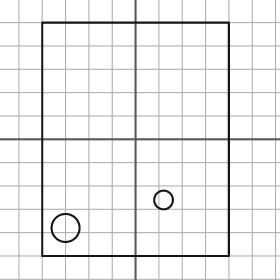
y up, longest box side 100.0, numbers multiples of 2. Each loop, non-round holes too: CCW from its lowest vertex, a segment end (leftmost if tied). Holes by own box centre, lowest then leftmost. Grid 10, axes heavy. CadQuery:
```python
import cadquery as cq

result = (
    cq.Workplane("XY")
    .moveTo(-40.0, -50.0)
    .lineTo(40.0, -50.0)
    .lineTo(40.0, 50.0)
    .lineTo(-40.0, 50.0)
    .close()
    .moveTo(-30.0, -38.0)
    .circle(6.0)
    .moveTo(12.0, -26.0)
    .circle(4.0)
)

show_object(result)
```